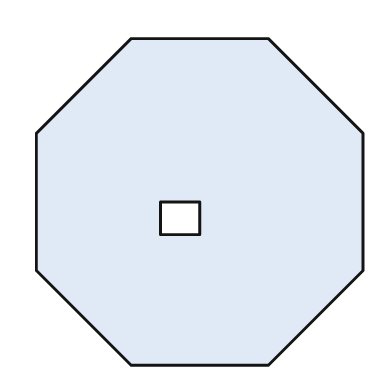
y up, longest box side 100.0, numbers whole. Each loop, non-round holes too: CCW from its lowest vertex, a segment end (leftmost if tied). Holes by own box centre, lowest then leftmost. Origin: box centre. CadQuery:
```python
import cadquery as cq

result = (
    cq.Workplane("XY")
    .moveTo(-21.0, -50.0)
    .lineTo(21.0, -50.0)
    .lineTo(50.0, -21.0)
    .lineTo(50.0, 21.0)
    .lineTo(21.0, 50.0)
    .lineTo(-21.0, 50.0)
    .lineTo(-50.0, 21.0)
    .lineTo(-50.0, -21.0)
    .close()
    .moveTo(-12.0, -10.0)
    .lineTo(0.0, -10.0)
    .lineTo(0.0, 0.0)
    .lineTo(-12.0, 0.0)
    .close()
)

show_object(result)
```